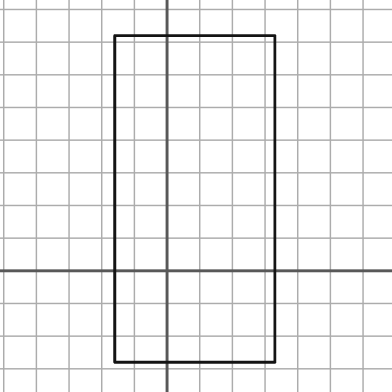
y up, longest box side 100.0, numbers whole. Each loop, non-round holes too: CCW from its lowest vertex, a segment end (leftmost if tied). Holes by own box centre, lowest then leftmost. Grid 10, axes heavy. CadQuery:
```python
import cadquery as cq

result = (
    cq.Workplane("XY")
    .moveTo(-16.0, -28.0)
    .lineTo(33.0, -28.0)
    .lineTo(33.0, 72.0)
    .lineTo(-16.0, 72.0)
    .close()
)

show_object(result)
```